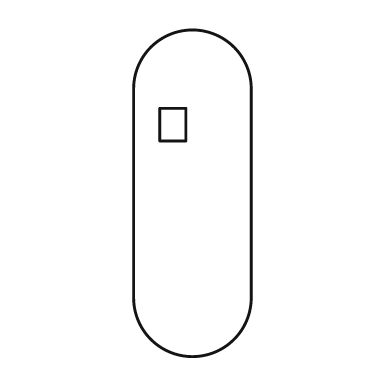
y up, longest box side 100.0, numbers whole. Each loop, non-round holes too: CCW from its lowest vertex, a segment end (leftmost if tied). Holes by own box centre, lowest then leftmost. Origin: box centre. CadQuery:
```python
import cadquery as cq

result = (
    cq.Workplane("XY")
    .moveTo(-18.0, -32.0)
    .threePointArc((0.0, -50.0), (18.0, -32.0))
    .lineTo(18.0, 32.0)
    .threePointArc((0.0, 50.0), (-18.0, 32.0))
    .close()
    .moveTo(-10.0, 16.0)
    .lineTo(-2.0, 16.0)
    .lineTo(-2.0, 26.0)
    .lineTo(-10.0, 26.0)
    .close()
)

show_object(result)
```